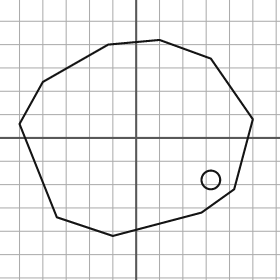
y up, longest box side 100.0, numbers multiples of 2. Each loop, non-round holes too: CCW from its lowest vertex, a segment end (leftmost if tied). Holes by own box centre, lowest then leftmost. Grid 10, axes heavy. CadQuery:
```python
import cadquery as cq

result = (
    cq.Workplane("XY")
    .moveTo(-10.0, -42.0)
    .lineTo(28.0, -32.0)
    .lineTo(42.0, -22.0)
    .lineTo(50.0, 8.0)
    .lineTo(32.0, 34.0)
    .lineTo(10.0, 42.0)
    .lineTo(-12.0, 40.0)
    .lineTo(-40.0, 24.0)
    .lineTo(-50.0, 6.0)
    .lineTo(-34.0, -34.0)
    .close()
    .moveTo(32.0, -18.0)
    .circle(4.0)
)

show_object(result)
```